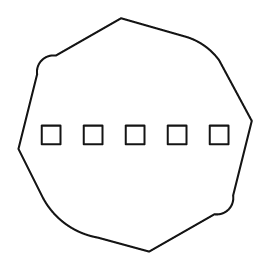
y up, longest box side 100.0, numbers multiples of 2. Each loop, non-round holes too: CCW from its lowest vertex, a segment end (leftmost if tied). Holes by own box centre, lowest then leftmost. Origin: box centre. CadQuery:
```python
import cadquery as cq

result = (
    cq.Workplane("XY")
    .moveTo(6.0, -50.0)
    .lineTo(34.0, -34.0)
    .threePointArc((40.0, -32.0), (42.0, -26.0))
    .lineTo(50.0, 6.0)
    .lineTo(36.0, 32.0)
    .threePointArc((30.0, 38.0), (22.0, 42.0))
    .lineTo(-6.0, 50.0)
    .lineTo(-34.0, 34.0)
    .threePointArc((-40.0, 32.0), (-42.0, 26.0))
    .lineTo(-50.0, -6.0)
    .lineTo(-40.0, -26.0)
    .threePointArc((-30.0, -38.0), (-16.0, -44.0))
    .close()
    .moveTo(-40.0, -4.0)
    .lineTo(-32.0, -4.0)
    .lineTo(-32.0, 4.0)
    .lineTo(-40.0, 4.0)
    .close()
    .moveTo(-22.0, -4.0)
    .lineTo(-14.0, -4.0)
    .lineTo(-14.0, 4.0)
    .lineTo(-22.0, 4.0)
    .close()
    .moveTo(-4.0, -4.0)
    .lineTo(4.0, -4.0)
    .lineTo(4.0, 4.0)
    .lineTo(-4.0, 4.0)
    .close()
    .moveTo(14.0, -4.0)
    .lineTo(22.0, -4.0)
    .lineTo(22.0, 4.0)
    .lineTo(14.0, 4.0)
    .close()
    .moveTo(32.0, -4.0)
    .lineTo(40.0, -4.0)
    .lineTo(40.0, 4.0)
    .lineTo(32.0, 4.0)
    .close()
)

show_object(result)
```